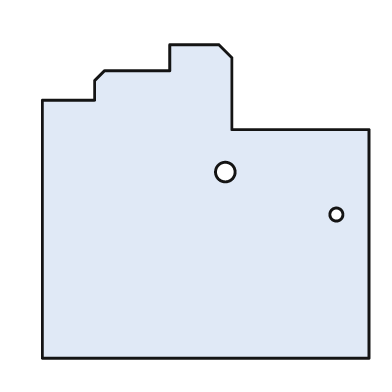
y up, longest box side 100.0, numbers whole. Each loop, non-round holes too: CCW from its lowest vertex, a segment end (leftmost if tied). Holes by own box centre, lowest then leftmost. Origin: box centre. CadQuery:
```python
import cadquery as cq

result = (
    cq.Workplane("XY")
    .moveTo(-50.0, -48.0)
    .lineTo(50.0, -48.0)
    .lineTo(50.0, 22.0)
    .lineTo(8.0, 22.0)
    .lineTo(8.0, 44.0)
    .lineTo(4.0, 48.0)
    .lineTo(-11.0, 48.0)
    .lineTo(-11.0, 40.0)
    .lineTo(-31.0, 40.0)
    .lineTo(-34.0, 37.0)
    .lineTo(-34.0, 31.0)
    .lineTo(-50.0, 31.0)
    .close()
    .moveTo(40.0, -4.0)
    .circle(2.0)
    .moveTo(6.0, 9.0)
    .circle(3.0)
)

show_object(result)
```